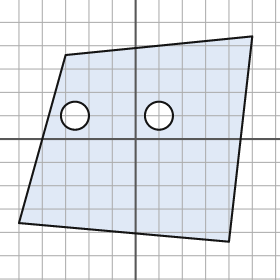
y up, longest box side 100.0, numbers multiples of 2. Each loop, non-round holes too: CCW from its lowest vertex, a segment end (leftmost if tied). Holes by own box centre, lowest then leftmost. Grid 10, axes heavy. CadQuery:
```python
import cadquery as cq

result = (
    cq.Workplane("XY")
    .moveTo(40.0, -44.0)
    .lineTo(50.0, 44.0)
    .lineTo(-30.0, 36.0)
    .lineTo(-50.0, -36.0)
    .close()
    .moveTo(-26.0, 10.0)
    .circle(6.0)
    .moveTo(10.0, 10.0)
    .circle(6.0)
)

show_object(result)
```